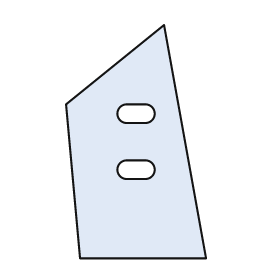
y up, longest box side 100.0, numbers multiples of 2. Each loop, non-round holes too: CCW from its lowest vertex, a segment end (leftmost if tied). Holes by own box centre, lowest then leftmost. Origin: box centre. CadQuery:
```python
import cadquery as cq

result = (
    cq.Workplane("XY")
    .moveTo(-24.0, -50.0)
    .lineTo(30.0, -50.0)
    .lineTo(12.0, 50.0)
    .lineTo(-30.0, 16.0)
    .close()
    .moveTo(-4.0, -16.0)
    .lineTo(4.0, -16.0)
    .threePointArc((8.0, -12.0), (4.0, -8.0))
    .lineTo(-4.0, -8.0)
    .threePointArc((-8.0, -12.0), (-4.0, -16.0))
    .close()
    .moveTo(-4.0, 8.0)
    .lineTo(4.0, 8.0)
    .threePointArc((8.0, 12.0), (4.0, 16.0))
    .lineTo(-4.0, 16.0)
    .threePointArc((-8.0, 12.0), (-4.0, 8.0))
    .close()
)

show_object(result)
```